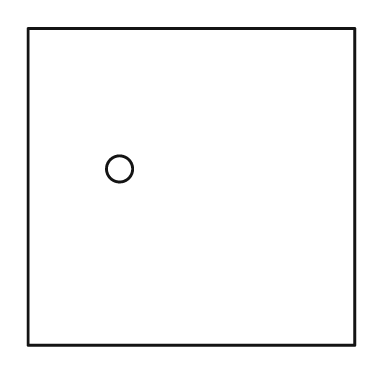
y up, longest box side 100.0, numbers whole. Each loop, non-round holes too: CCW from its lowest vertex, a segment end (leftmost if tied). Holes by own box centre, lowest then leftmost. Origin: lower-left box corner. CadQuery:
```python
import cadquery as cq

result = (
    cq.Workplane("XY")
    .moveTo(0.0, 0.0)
    .lineTo(100.0, 0.0)
    .lineTo(100.0, 97.0)
    .lineTo(0.0, 97.0)
    .close()
    .moveTo(28.0, 54.0)
    .circle(4.0)
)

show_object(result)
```